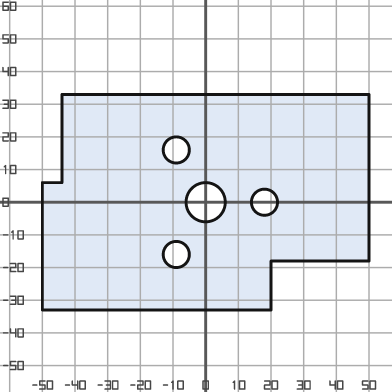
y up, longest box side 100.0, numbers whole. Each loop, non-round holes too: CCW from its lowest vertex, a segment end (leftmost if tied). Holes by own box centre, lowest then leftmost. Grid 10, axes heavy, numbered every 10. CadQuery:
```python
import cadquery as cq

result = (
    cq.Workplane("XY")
    .moveTo(-50.0, -33.0)
    .lineTo(20.0, -33.0)
    .lineTo(20.0, -18.0)
    .lineTo(50.0, -18.0)
    .lineTo(50.0, 33.0)
    .lineTo(-44.0, 33.0)
    .lineTo(-44.0, 6.0)
    .lineTo(-50.0, 6.0)
    .close()
    .moveTo(-9.0, -16.0)
    .circle(4.0)
    .moveTo(0.0, 0.0)
    .circle(6.0)
    .moveTo(18.0, 0.0)
    .circle(4.0)
    .moveTo(-9.0, 16.0)
    .circle(4.0)
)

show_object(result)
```